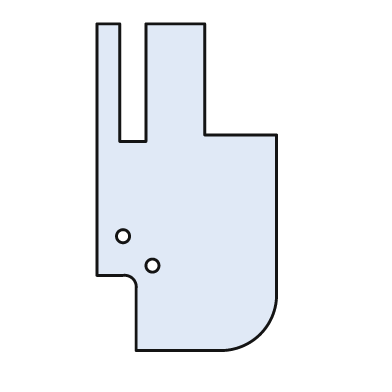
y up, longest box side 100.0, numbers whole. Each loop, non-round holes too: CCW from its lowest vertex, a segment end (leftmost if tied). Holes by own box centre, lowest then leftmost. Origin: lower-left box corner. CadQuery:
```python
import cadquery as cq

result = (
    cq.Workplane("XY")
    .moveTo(12.0, 0.0)
    .lineTo(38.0, 0.0)
    .threePointArc((50.0, 5.0), (55.0, 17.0))
    .lineTo(55.0, 66.0)
    .lineTo(33.0, 66.0)
    .lineTo(33.0, 100.0)
    .lineTo(15.0, 100.0)
    .lineTo(15.0, 64.0)
    .lineTo(7.0, 64.0)
    .lineTo(7.0, 100.0)
    .lineTo(0.0, 100.0)
    .lineTo(0.0, 23.0)
    .lineTo(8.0, 23.0)
    .threePointArc((11.0, 22.0), (12.0, 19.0))
    .close()
    .moveTo(17.0, 26.0)
    .circle(2.0)
    .moveTo(8.0, 35.0)
    .circle(2.0)
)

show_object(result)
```